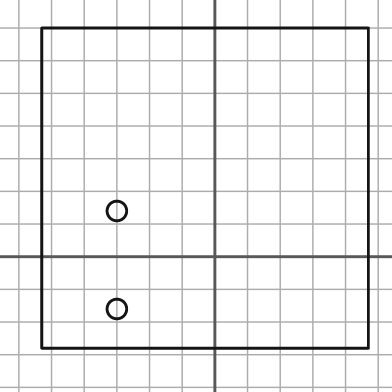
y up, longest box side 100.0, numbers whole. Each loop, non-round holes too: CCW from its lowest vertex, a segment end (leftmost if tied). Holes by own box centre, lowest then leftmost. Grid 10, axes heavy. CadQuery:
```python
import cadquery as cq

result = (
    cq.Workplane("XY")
    .moveTo(-53.0, -28.0)
    .lineTo(47.0, -28.0)
    .lineTo(47.0, 70.0)
    .lineTo(-53.0, 70.0)
    .close()
    .moveTo(-30.0, -16.0)
    .circle(3.0)
    .moveTo(-30.0, 14.0)
    .circle(3.0)
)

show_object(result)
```